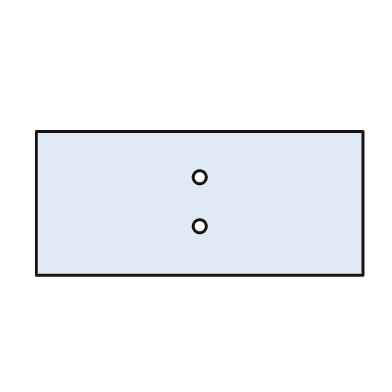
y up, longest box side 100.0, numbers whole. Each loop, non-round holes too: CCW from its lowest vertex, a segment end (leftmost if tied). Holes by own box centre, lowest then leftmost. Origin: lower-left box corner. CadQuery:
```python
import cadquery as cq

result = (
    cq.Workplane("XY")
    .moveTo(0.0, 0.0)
    .lineTo(100.0, 0.0)
    .lineTo(100.0, 44.0)
    .lineTo(0.0, 44.0)
    .close()
    .moveTo(50.0, 15.0)
    .circle(2.0)
    .moveTo(50.0, 30.0)
    .circle(2.0)
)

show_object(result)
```